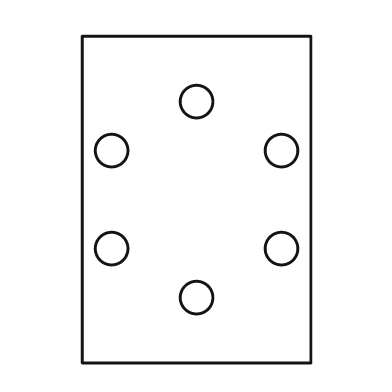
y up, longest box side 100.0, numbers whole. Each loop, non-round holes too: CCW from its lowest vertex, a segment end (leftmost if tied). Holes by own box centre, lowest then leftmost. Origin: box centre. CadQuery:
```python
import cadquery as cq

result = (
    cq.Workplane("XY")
    .moveTo(-35.0, -50.0)
    .lineTo(35.0, -50.0)
    .lineTo(35.0, 50.0)
    .lineTo(-35.0, 50.0)
    .close()
    .moveTo(0.0, -30.0)
    .circle(5.0)
    .moveTo(-26.0, -15.0)
    .circle(5.0)
    .moveTo(26.0, -15.0)
    .circle(5.0)
    .moveTo(-26.0, 15.0)
    .circle(5.0)
    .moveTo(26.0, 15.0)
    .circle(5.0)
    .moveTo(0.0, 30.0)
    .circle(5.0)
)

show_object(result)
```